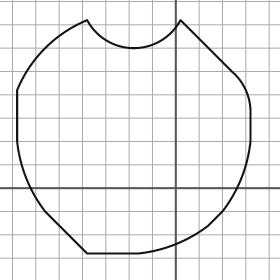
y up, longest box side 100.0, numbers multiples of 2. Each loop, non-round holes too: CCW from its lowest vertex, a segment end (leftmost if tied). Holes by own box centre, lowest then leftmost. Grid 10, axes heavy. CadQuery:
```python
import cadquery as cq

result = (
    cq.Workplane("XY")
    .moveTo(-38.0, -28.0)
    .lineTo(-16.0, -28.0)
    .threePointArc((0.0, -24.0), (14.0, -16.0))
    .lineTo(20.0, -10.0)
    .threePointArc((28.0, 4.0), (32.0, 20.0))
    .lineTo(32.0, 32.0)
    .threePointArc((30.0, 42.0), (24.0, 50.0))
    .lineTo(2.0, 72.0)
    .threePointArc((-18.0, 60.0), (-38.0, 72.0))
    .threePointArc((-56.0, 60.0), (-68.0, 42.0))
    .lineTo(-68.0, 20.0)
    .threePointArc((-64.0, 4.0), (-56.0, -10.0))
    .close()
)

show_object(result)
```